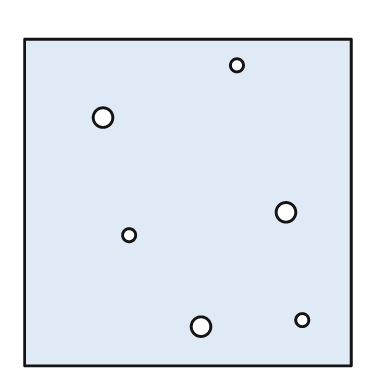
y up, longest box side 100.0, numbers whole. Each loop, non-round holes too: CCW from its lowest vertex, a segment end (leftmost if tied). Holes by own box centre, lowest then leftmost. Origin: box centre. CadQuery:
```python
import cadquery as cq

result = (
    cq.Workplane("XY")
    .moveTo(-50.0, -50.0)
    .lineTo(50.0, -50.0)
    .lineTo(50.0, 50.0)
    .lineTo(-50.0, 50.0)
    .close()
    .moveTo(4.0, -38.0)
    .circle(3.0)
    .moveTo(35.0, -36.0)
    .circle(2.0)
    .moveTo(-18.0, -10.0)
    .circle(2.0)
    .moveTo(30.0, -3.0)
    .circle(3.0)
    .moveTo(-26.0, 26.0)
    .circle(3.0)
    .moveTo(15.0, 42.0)
    .circle(2.0)
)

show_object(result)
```